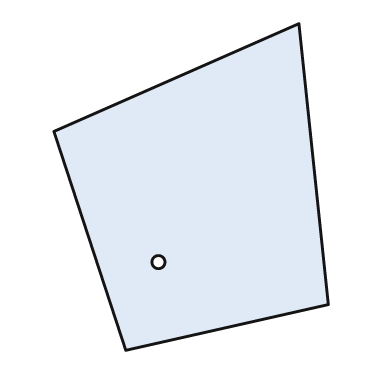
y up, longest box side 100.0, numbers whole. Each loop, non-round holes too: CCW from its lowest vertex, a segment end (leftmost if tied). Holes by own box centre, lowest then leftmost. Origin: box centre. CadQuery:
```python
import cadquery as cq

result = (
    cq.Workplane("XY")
    .moveTo(-20.0, -50.0)
    .lineTo(42.0, -36.0)
    .lineTo(33.0, 50.0)
    .lineTo(-42.0, 17.0)
    .close()
    .moveTo(-10.0, -23.0)
    .circle(2.0)
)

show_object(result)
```